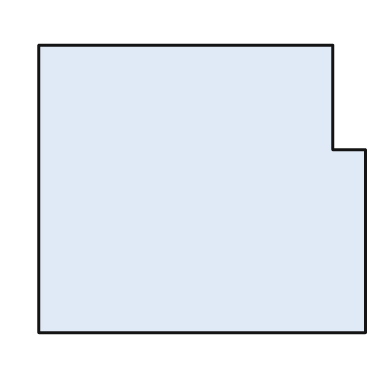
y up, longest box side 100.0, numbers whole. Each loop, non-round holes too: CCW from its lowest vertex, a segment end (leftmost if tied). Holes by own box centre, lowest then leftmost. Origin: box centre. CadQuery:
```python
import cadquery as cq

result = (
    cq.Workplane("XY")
    .moveTo(-50.0, -44.0)
    .lineTo(50.0, -44.0)
    .lineTo(50.0, 12.0)
    .lineTo(40.0, 12.0)
    .lineTo(40.0, 44.0)
    .lineTo(-50.0, 44.0)
    .close()
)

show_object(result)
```